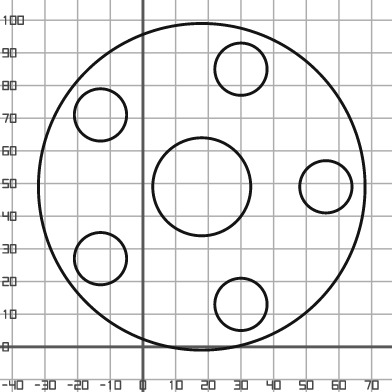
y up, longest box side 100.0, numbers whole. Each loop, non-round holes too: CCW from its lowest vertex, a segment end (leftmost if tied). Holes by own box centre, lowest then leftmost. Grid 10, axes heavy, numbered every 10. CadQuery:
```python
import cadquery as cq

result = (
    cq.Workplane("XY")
    .moveTo(18.0, 49.0)
    .circle(50.0)
    .moveTo(30.0, 13.0)
    .circle(8.0)
    .moveTo(-13.0, 27.0)
    .circle(8.0)
    .moveTo(18.0, 49.0)
    .circle(15.0)
    .moveTo(56.0, 49.0)
    .circle(8.0)
    .moveTo(-13.0, 71.0)
    .circle(8.0)
    .moveTo(30.0, 85.0)
    .circle(8.0)
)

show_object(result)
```